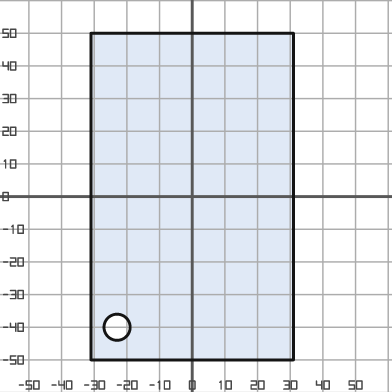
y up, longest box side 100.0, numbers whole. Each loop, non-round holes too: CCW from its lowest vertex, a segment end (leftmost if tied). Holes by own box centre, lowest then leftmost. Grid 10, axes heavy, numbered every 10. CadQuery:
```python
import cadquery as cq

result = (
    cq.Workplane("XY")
    .moveTo(-31.0, -50.0)
    .lineTo(31.0, -50.0)
    .lineTo(31.0, 50.0)
    .lineTo(-31.0, 50.0)
    .close()
    .moveTo(-23.0, -40.0)
    .circle(4.0)
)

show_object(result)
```